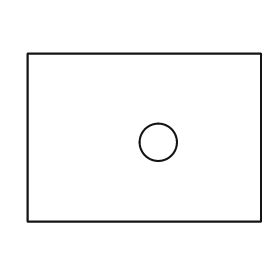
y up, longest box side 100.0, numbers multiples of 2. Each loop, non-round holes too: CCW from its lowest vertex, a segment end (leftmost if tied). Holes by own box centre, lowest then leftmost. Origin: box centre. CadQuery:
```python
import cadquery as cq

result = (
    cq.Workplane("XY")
    .moveTo(-50.0, -36.0)
    .lineTo(50.0, -36.0)
    .lineTo(50.0, 36.0)
    .lineTo(-50.0, 36.0)
    .close()
    .moveTo(6.0, -2.0)
    .circle(8.0)
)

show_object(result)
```